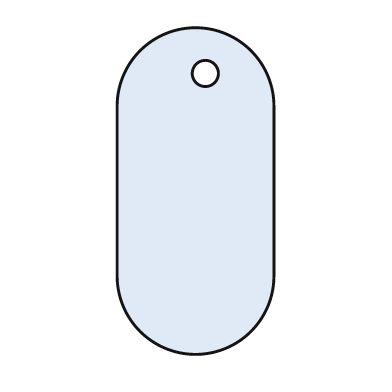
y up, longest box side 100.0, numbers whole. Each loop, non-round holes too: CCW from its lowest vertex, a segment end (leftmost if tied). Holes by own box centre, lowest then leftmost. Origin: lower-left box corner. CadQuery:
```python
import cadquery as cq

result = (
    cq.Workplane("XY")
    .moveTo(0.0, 24.0)
    .threePointArc((24.0, 0.0), (48.0, 24.0))
    .lineTo(48.0, 76.0)
    .threePointArc((24.0, 100.0), (0.0, 76.0))
    .close()
    .moveTo(27.0, 86.0)
    .circle(4.0)
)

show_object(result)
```